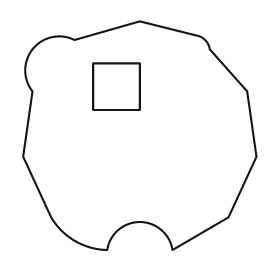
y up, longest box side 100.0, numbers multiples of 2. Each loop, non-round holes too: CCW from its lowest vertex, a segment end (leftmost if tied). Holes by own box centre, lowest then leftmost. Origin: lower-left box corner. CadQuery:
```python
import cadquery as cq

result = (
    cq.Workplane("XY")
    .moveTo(36.0, 0.0)
    .threePointArc((50.0, 12.0), (64.0, 0.0))
    .lineTo(88.0, 14.0)
    .lineTo(100.0, 40.0)
    .lineTo(96.0, 68.0)
    .lineTo(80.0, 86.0)
    .threePointArc((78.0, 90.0), (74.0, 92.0))
    .lineTo(50.0, 98.0)
    .lineTo(22.0, 90.0)
    .threePointArc((4.0, 86.0), (4.0, 68.0))
    .lineTo(0.0, 40.0)
    .lineTo(12.0, 14.0)
    .threePointArc((22.0, 4.0), (36.0, 0.0))
    .close()
    .moveTo(30.0, 60.0)
    .lineTo(50.0, 60.0)
    .lineTo(50.0, 80.0)
    .lineTo(30.0, 80.0)
    .close()
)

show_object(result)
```